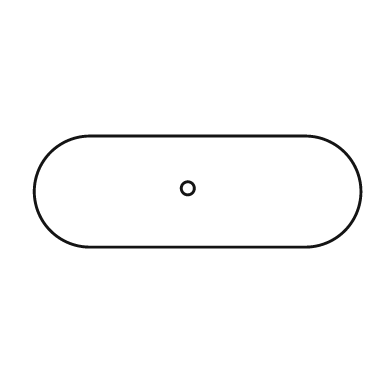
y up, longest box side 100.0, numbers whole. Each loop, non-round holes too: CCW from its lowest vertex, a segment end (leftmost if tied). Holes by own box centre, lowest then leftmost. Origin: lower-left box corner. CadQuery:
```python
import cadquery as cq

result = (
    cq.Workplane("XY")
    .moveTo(17.0, 0.0)
    .lineTo(83.0, 0.0)
    .threePointArc((100.0, 17.0), (83.0, 34.0))
    .lineTo(17.0, 34.0)
    .threePointArc((0.0, 17.0), (17.0, 0.0))
    .close()
    .moveTo(47.0, 18.0)
    .circle(2.0)
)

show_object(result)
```